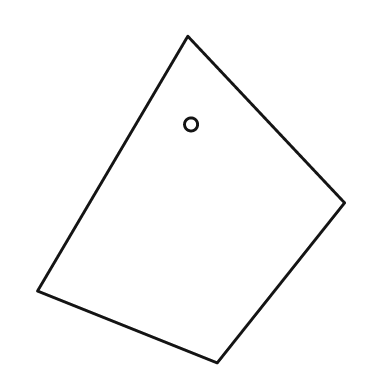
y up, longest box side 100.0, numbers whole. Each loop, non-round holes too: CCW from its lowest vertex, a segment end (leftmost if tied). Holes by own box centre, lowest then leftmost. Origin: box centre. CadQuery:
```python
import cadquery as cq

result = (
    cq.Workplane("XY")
    .moveTo(8.0, -50.0)
    .lineTo(47.0, -1.0)
    .lineTo(-1.0, 50.0)
    .lineTo(-47.0, -28.0)
    .close()
    .moveTo(0.0, 23.0)
    .circle(2.0)
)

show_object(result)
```